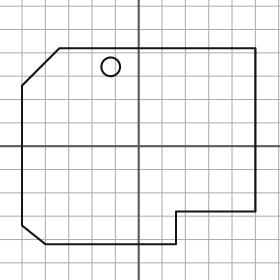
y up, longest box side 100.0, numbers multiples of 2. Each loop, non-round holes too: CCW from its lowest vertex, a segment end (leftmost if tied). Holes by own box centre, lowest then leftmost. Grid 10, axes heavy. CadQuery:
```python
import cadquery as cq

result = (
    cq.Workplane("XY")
    .moveTo(-40.0, -42.0)
    .lineTo(16.0, -42.0)
    .lineTo(16.0, -28.0)
    .lineTo(50.0, -28.0)
    .lineTo(50.0, 42.0)
    .lineTo(-34.0, 42.0)
    .lineTo(-50.0, 26.0)
    .lineTo(-50.0, -34.0)
    .close()
    .moveTo(-12.0, 34.0)
    .circle(4.0)
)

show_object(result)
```